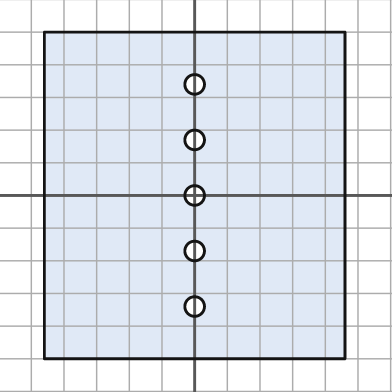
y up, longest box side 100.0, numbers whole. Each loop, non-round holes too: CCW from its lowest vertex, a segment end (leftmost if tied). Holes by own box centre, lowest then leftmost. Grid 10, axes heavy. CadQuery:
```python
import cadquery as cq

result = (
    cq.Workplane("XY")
    .moveTo(-46.0, -50.0)
    .lineTo(46.0, -50.0)
    .lineTo(46.0, 50.0)
    .lineTo(-46.0, 50.0)
    .close()
    .moveTo(0.0, -34.0)
    .circle(3.0)
    .moveTo(0.0, -17.0)
    .circle(3.0)
    .moveTo(0.0, 0.0)
    .circle(3.0)
    .moveTo(0.0, 17.0)
    .circle(3.0)
    .moveTo(0.0, 34.0)
    .circle(3.0)
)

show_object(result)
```